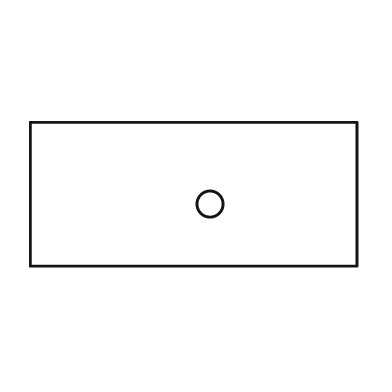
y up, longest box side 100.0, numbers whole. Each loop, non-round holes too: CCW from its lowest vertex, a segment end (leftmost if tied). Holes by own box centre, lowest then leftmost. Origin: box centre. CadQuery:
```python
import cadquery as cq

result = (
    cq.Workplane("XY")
    .moveTo(-50.0, -22.0)
    .lineTo(50.0, -22.0)
    .lineTo(50.0, 22.0)
    .lineTo(-50.0, 22.0)
    .close()
    .moveTo(5.0, -3.0)
    .circle(4.0)
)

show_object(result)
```